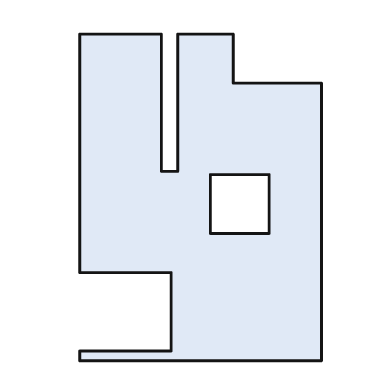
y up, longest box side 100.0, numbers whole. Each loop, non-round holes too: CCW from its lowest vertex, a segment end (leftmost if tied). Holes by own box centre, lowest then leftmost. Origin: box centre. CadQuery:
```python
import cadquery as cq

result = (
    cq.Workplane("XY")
    .moveTo(-37.0, -50.0)
    .lineTo(37.0, -50.0)
    .lineTo(37.0, 35.0)
    .lineTo(10.0, 35.0)
    .lineTo(10.0, 50.0)
    .lineTo(-7.0, 50.0)
    .lineTo(-7.0, 8.0)
    .lineTo(-12.0, 8.0)
    .lineTo(-12.0, 50.0)
    .lineTo(-37.0, 50.0)
    .lineTo(-37.0, -23.0)
    .lineTo(-9.0, -23.0)
    .lineTo(-9.0, -47.0)
    .lineTo(-37.0, -47.0)
    .close()
    .moveTo(3.0, -11.0)
    .lineTo(21.0, -11.0)
    .lineTo(21.0, 7.0)
    .lineTo(3.0, 7.0)
    .close()
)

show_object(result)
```